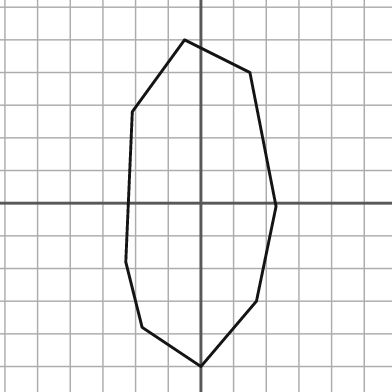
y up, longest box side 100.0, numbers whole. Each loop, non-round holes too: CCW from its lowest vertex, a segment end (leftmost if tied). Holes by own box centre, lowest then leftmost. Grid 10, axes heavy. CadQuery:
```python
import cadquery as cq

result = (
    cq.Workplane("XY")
    .moveTo(0.0, -50.0)
    .lineTo(17.0, -30.0)
    .lineTo(23.0, -1.0)
    .lineTo(15.0, 40.0)
    .lineTo(-5.0, 50.0)
    .lineTo(-21.0, 28.0)
    .lineTo(-23.0, -18.0)
    .lineTo(-18.0, -38.0)
    .close()
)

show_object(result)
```